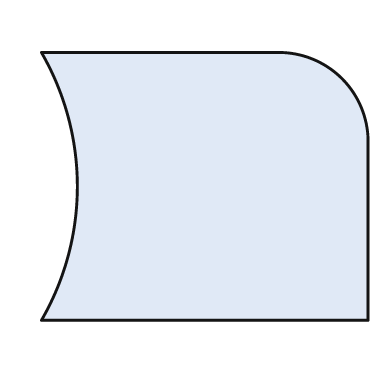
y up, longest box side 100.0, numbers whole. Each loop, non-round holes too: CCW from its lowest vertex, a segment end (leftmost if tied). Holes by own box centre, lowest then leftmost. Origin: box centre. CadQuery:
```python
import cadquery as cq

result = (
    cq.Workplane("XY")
    .moveTo(-50.0, -41.0)
    .lineTo(50.0, -41.0)
    .lineTo(50.0, 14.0)
    .threePointArc((42.0, 33.0), (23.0, 41.0))
    .lineTo(-50.0, 41.0)
    .threePointArc((-39.0, 0.0), (-50.0, -41.0))
    .close()
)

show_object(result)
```